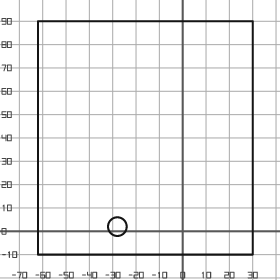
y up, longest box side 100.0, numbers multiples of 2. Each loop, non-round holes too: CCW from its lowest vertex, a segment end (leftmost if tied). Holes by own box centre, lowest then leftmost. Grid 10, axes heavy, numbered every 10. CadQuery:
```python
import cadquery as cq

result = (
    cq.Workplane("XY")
    .moveTo(-62.0, -10.0)
    .lineTo(30.0, -10.0)
    .lineTo(30.0, 90.0)
    .lineTo(-62.0, 90.0)
    .close()
    .moveTo(-28.0, 2.0)
    .circle(4.0)
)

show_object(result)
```